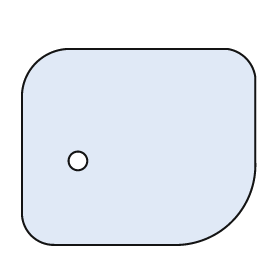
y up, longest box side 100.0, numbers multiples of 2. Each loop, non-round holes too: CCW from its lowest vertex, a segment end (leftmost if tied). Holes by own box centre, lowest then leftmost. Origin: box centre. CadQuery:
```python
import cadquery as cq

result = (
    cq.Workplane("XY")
    .moveTo(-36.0, -42.0)
    .lineTo(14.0, -42.0)
    .threePointArc((40.0, -32.0), (50.0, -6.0))
    .lineTo(50.0, 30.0)
    .threePointArc((46.0, 38.0), (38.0, 42.0))
    .lineTo(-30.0, 42.0)
    .threePointArc((-44.0, 36.0), (-50.0, 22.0))
    .lineTo(-50.0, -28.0)
    .threePointArc((-46.0, -38.0), (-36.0, -42.0))
    .close()
    .moveTo(-26.0, -6.0)
    .circle(4.0)
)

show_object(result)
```